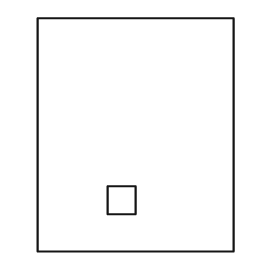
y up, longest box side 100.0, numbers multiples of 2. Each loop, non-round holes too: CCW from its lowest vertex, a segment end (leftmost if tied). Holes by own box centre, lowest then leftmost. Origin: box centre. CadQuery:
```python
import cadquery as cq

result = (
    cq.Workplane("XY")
    .moveTo(-42.0, -50.0)
    .lineTo(42.0, -50.0)
    .lineTo(42.0, 50.0)
    .lineTo(-42.0, 50.0)
    .close()
    .moveTo(-12.0, -34.0)
    .lineTo(0.0, -34.0)
    .lineTo(0.0, -22.0)
    .lineTo(-12.0, -22.0)
    .close()
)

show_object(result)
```